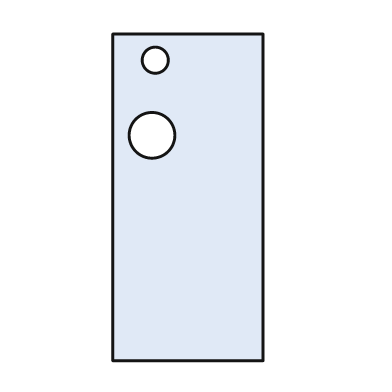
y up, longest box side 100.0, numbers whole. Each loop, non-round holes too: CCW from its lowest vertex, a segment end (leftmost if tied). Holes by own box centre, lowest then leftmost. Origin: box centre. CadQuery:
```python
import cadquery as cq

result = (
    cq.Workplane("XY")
    .moveTo(-23.0, -50.0)
    .lineTo(23.0, -50.0)
    .lineTo(23.0, 50.0)
    .lineTo(-23.0, 50.0)
    .close()
    .moveTo(-11.0, 19.0)
    .circle(7.0)
    .moveTo(-10.0, 42.0)
    .circle(4.0)
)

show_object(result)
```